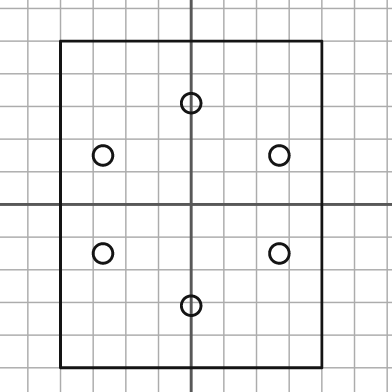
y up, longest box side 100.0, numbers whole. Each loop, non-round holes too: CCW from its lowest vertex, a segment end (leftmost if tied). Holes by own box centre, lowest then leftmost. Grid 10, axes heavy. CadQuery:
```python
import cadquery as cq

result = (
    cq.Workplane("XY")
    .moveTo(-40.0, -50.0)
    .lineTo(40.0, -50.0)
    .lineTo(40.0, 50.0)
    .lineTo(-40.0, 50.0)
    .close()
    .moveTo(0.0, -31.0)
    .circle(3.0)
    .moveTo(-27.0, -15.0)
    .circle(3.0)
    .moveTo(27.0, -15.0)
    .circle(3.0)
    .moveTo(-27.0, 15.0)
    .circle(3.0)
    .moveTo(27.0, 15.0)
    .circle(3.0)
    .moveTo(0.0, 31.0)
    .circle(3.0)
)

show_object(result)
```